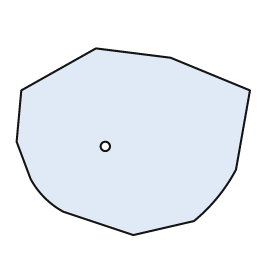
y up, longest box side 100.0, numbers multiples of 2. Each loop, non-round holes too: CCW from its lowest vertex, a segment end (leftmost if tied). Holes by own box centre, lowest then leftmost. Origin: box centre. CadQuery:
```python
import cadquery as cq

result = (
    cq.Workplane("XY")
    .moveTo(0.0, -40.0)
    .lineTo(26.0, -34.0)
    .threePointArc((36.0, -24.0), (44.0, -12.0))
    .lineTo(50.0, 22.0)
    .lineTo(16.0, 36.0)
    .lineTo(-16.0, 40.0)
    .lineTo(-48.0, 22.0)
    .lineTo(-50.0, 0.0)
    .lineTo(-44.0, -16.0)
    .threePointArc((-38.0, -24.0), (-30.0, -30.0))
    .close()
    .moveTo(-12.0, -2.0)
    .circle(2.0)
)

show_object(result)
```